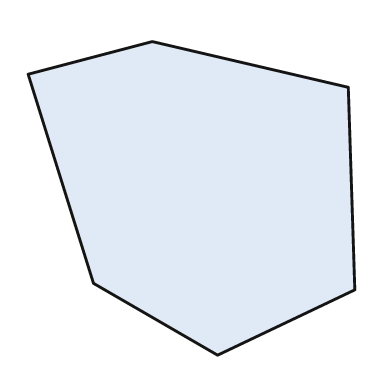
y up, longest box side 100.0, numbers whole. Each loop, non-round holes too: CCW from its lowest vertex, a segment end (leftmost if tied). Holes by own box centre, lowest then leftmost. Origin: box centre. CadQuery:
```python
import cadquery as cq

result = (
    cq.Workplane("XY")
    .moveTo(8.0, -48.0)
    .lineTo(50.0, -28.0)
    .lineTo(48.0, 34.0)
    .lineTo(-12.0, 48.0)
    .lineTo(-50.0, 38.0)
    .lineTo(-30.0, -26.0)
    .close()
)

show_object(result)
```